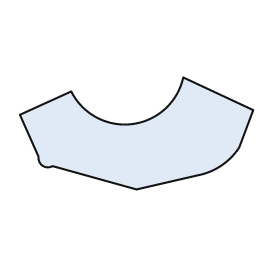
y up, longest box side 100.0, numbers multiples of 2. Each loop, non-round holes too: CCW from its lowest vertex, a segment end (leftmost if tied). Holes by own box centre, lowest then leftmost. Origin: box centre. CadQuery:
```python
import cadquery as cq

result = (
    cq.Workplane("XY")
    .moveTo(0.0, -24.0)
    .lineTo(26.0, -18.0)
    .threePointArc((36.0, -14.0), (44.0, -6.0))
    .lineTo(50.0, 10.0)
    .lineTo(20.0, 24.0)
    .threePointArc((-2.0, 4.0), (-28.0, 18.0))
    .lineTo(-50.0, 8.0)
    .lineTo(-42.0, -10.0)
    .threePointArc((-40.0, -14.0), (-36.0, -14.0))
    .close()
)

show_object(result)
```